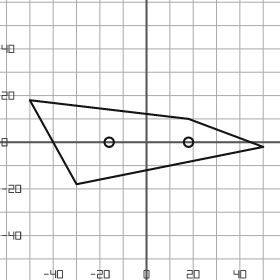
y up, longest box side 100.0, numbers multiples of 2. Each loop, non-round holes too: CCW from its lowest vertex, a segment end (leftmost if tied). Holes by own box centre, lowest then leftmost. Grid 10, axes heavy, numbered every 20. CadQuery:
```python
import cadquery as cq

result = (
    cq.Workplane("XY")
    .moveTo(-30.0, -18.0)
    .lineTo(50.0, -2.0)
    .lineTo(18.0, 10.0)
    .lineTo(-50.0, 18.0)
    .close()
    .moveTo(-16.0, 0.0)
    .circle(2.0)
    .moveTo(18.0, 0.0)
    .circle(2.0)
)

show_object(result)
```